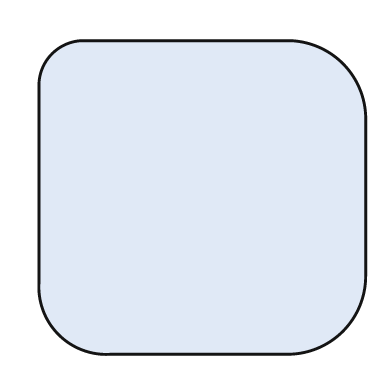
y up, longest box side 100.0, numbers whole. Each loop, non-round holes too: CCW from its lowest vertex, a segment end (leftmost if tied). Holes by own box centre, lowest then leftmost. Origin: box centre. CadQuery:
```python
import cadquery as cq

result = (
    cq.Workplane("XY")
    .moveTo(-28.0, -48.0)
    .lineTo(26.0, -48.0)
    .threePointArc((43.0, -41.0), (50.0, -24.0))
    .lineTo(50.0, 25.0)
    .threePointArc((43.0, 41.0), (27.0, 48.0))
    .lineTo(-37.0, 48.0)
    .threePointArc((-46.0, 44.0), (-50.0, 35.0))
    .lineTo(-50.0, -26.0)
    .threePointArc((-44.0, -42.0), (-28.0, -48.0))
    .close()
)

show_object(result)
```